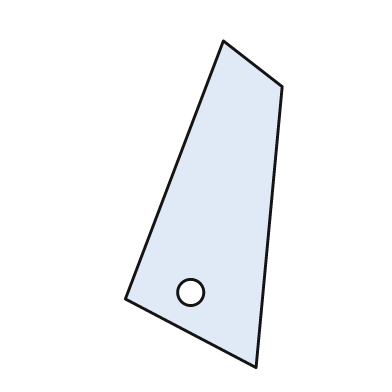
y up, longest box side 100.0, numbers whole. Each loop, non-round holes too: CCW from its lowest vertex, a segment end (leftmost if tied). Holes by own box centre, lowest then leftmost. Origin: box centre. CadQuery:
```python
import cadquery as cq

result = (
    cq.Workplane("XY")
    .moveTo(16.0, -50.0)
    .lineTo(24.0, 36.0)
    .lineTo(6.0, 50.0)
    .lineTo(-24.0, -29.0)
    .close()
    .moveTo(-4.0, -27.0)
    .circle(4.0)
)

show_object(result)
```